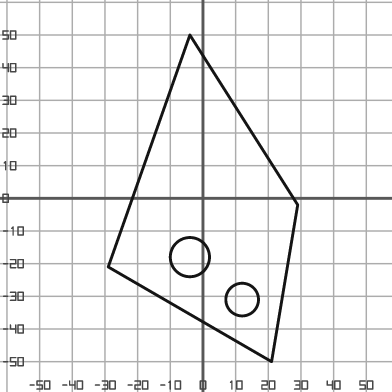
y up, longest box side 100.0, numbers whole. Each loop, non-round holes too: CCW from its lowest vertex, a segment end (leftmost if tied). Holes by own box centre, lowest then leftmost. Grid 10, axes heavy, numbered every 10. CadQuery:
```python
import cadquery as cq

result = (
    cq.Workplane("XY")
    .moveTo(21.0, -50.0)
    .lineTo(29.0, -2.0)
    .lineTo(-4.0, 50.0)
    .lineTo(-29.0, -21.0)
    .close()
    .moveTo(12.0, -31.0)
    .circle(5.0)
    .moveTo(-4.0, -18.0)
    .circle(6.0)
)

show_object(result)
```